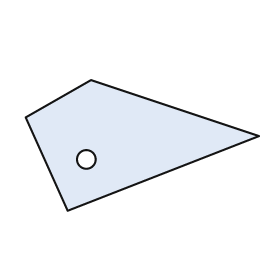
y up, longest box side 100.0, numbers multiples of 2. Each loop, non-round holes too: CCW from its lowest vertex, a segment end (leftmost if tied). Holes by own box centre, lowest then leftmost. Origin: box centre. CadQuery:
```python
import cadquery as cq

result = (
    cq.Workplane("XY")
    .moveTo(-32.0, -28.0)
    .lineTo(50.0, 4.0)
    .lineTo(-22.0, 28.0)
    .lineTo(-50.0, 12.0)
    .close()
    .moveTo(-24.0, -6.0)
    .circle(4.0)
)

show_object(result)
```